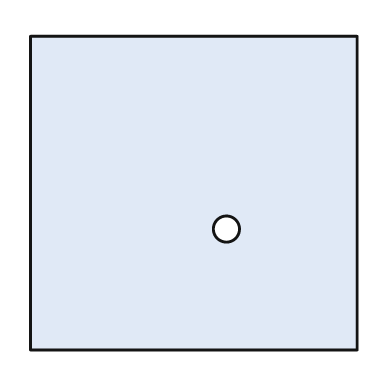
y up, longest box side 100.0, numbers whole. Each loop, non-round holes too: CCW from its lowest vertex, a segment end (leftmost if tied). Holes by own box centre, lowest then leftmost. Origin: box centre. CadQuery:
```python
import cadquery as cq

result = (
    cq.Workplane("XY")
    .moveTo(-50.0, -48.0)
    .lineTo(50.0, -48.0)
    .lineTo(50.0, 48.0)
    .lineTo(-50.0, 48.0)
    .close()
    .moveTo(10.0, -11.0)
    .circle(4.0)
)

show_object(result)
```